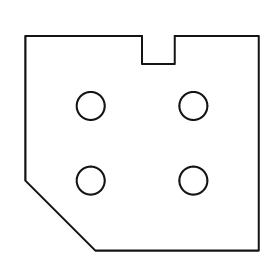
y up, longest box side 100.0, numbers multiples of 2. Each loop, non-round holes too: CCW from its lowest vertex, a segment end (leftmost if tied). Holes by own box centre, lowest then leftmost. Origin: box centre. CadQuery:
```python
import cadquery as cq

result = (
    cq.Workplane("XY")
    .moveTo(-20.0, -46.0)
    .lineTo(50.0, -46.0)
    .lineTo(50.0, 46.0)
    .lineTo(14.0, 46.0)
    .lineTo(14.0, 34.0)
    .lineTo(0.0, 34.0)
    .lineTo(0.0, 46.0)
    .lineTo(-50.0, 46.0)
    .lineTo(-50.0, -16.0)
    .close()
    .moveTo(-22.0, -16.0)
    .circle(6.0)
    .moveTo(22.0, -16.0)
    .circle(6.0)
    .moveTo(-22.0, 16.0)
    .circle(6.0)
    .moveTo(22.0, 16.0)
    .circle(6.0)
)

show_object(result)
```